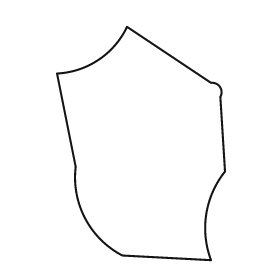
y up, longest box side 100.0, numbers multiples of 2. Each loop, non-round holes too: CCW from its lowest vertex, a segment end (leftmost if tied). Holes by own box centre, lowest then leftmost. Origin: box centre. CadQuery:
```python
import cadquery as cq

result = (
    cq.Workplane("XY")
    .moveTo(30.0, -50.0)
    .threePointArc((28.0, -30.0), (36.0, -12.0))
    .lineTo(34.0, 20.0)
    .threePointArc((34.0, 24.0), (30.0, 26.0))
    .lineTo(-6.0, 50.0)
    .threePointArc((-18.0, 36.0), (-36.0, 30.0))
    .lineTo(-28.0, -10.0)
    .threePointArc((-24.0, -32.0), (-8.0, -48.0))
    .close()
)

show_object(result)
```